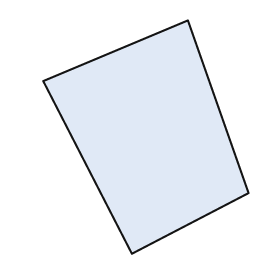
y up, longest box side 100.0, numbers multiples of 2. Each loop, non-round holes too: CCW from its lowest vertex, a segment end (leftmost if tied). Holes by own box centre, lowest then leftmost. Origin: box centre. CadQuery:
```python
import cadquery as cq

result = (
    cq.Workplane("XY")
    .moveTo(-6.0, -50.0)
    .lineTo(44.0, -24.0)
    .lineTo(18.0, 50.0)
    .lineTo(-44.0, 24.0)
    .close()
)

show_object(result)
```